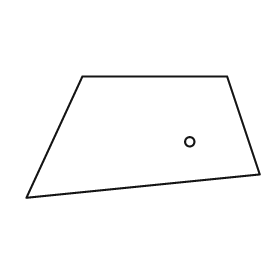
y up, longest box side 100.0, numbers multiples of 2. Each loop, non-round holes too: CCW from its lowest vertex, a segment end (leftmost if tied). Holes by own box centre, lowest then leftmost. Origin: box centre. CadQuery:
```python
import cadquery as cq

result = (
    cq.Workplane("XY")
    .moveTo(-50.0, -26.0)
    .lineTo(50.0, -16.0)
    .lineTo(36.0, 26.0)
    .lineTo(-26.0, 26.0)
    .close()
    .moveTo(20.0, -2.0)
    .circle(2.0)
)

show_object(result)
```